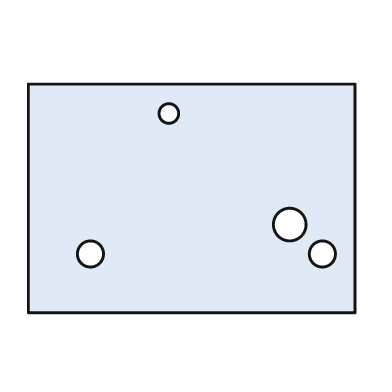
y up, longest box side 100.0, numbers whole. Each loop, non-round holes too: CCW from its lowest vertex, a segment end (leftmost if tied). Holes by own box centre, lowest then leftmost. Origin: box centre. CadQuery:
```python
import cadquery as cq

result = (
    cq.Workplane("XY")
    .moveTo(-50.0, -35.0)
    .lineTo(50.0, -35.0)
    .lineTo(50.0, 35.0)
    .lineTo(-50.0, 35.0)
    .close()
    .moveTo(-31.0, -17.0)
    .circle(4.0)
    .moveTo(40.0, -17.0)
    .circle(4.0)
    .moveTo(30.0, -8.0)
    .circle(5.0)
    .moveTo(-7.0, 26.0)
    .circle(3.0)
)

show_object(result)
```